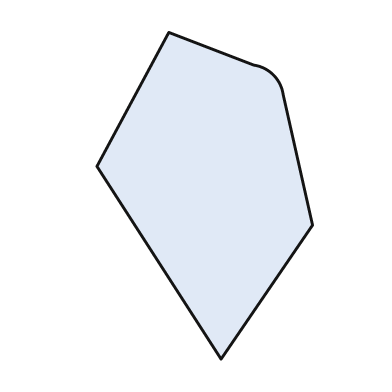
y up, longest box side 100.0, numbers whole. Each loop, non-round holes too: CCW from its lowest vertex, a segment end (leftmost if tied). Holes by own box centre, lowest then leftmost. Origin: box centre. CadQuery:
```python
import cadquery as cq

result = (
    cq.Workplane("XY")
    .moveTo(5.0, -50.0)
    .lineTo(33.0, -9.0)
    .lineTo(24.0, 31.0)
    .threePointArc((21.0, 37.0), (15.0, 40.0))
    .lineTo(-11.0, 50.0)
    .lineTo(-33.0, 9.0)
    .close()
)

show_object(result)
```